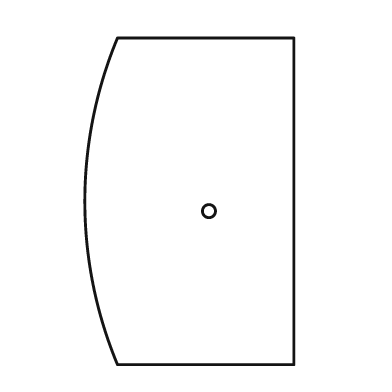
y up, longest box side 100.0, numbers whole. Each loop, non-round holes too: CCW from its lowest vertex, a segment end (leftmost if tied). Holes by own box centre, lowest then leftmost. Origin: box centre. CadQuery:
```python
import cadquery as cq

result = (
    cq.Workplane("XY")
    .moveTo(-22.0, -50.0)
    .lineTo(32.0, -50.0)
    .lineTo(32.0, 50.0)
    .lineTo(-22.0, 50.0)
    .threePointArc((-32.0, 0.0), (-22.0, -50.0))
    .close()
    .moveTo(6.0, -3.0)
    .circle(2.0)
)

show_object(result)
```